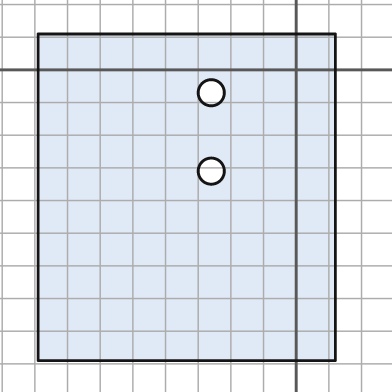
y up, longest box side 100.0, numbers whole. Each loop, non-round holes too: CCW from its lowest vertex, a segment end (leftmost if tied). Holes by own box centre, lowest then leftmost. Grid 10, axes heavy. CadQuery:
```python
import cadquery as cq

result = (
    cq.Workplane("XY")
    .moveTo(-79.0, -89.0)
    .lineTo(12.0, -89.0)
    .lineTo(12.0, 11.0)
    .lineTo(-79.0, 11.0)
    .close()
    .moveTo(-26.0, -31.0)
    .circle(4.0)
    .moveTo(-26.0, -7.0)
    .circle(4.0)
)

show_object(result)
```